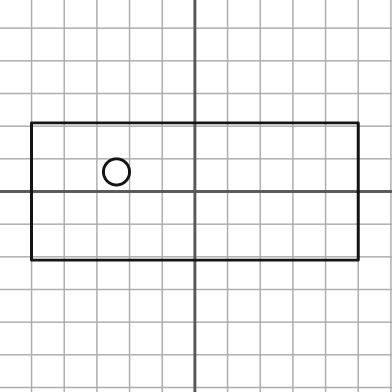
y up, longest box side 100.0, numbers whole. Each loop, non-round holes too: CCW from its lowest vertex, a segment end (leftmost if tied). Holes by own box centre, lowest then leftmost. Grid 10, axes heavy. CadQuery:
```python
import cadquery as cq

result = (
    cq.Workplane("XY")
    .moveTo(-50.0, -21.0)
    .lineTo(50.0, -21.0)
    .lineTo(50.0, 21.0)
    .lineTo(-50.0, 21.0)
    .close()
    .moveTo(-24.0, 6.0)
    .circle(4.0)
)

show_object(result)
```